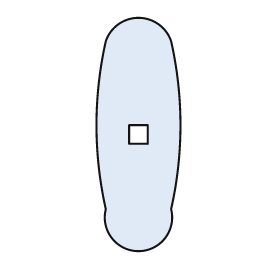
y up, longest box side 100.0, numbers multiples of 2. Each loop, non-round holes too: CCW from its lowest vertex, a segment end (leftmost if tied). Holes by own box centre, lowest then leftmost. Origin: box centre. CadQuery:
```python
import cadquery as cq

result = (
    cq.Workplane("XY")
    .moveTo(-14.0, -32.0)
    .threePointArc((0.0, -50.0), (14.0, -32.0))
    .threePointArc((18.0, 4.0), (14.0, 40.0))
    .threePointArc((0.0, 50.0), (-14.0, 40.0))
    .threePointArc((-18.0, 4.0), (-14.0, -32.0))
    .close()
    .moveTo(-4.0, -4.0)
    .lineTo(4.0, -4.0)
    .lineTo(4.0, 4.0)
    .lineTo(-4.0, 4.0)
    .close()
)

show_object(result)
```